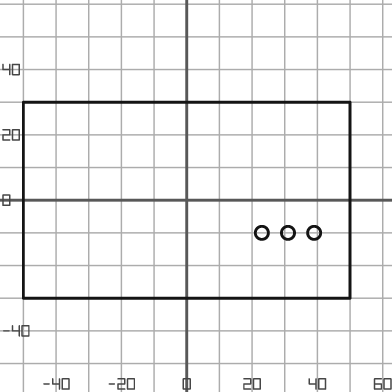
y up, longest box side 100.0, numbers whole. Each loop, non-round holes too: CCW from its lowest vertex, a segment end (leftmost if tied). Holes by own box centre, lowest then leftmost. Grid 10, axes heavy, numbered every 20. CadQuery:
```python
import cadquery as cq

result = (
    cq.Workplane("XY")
    .moveTo(-50.0, -30.0)
    .lineTo(50.0, -30.0)
    .lineTo(50.0, 30.0)
    .lineTo(-50.0, 30.0)
    .close()
    .moveTo(23.0, -10.0)
    .circle(2.0)
    .moveTo(31.0, -10.0)
    .circle(2.0)
    .moveTo(39.0, -10.0)
    .circle(2.0)
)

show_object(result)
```